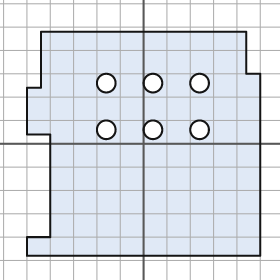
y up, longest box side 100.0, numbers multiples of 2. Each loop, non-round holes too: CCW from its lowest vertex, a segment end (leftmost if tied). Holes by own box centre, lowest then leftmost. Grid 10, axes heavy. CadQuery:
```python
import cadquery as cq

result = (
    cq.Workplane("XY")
    .moveTo(-50.0, -48.0)
    .lineTo(50.0, -48.0)
    .lineTo(50.0, 30.0)
    .lineTo(44.0, 30.0)
    .lineTo(44.0, 48.0)
    .lineTo(-44.0, 48.0)
    .lineTo(-44.0, 24.0)
    .lineTo(-50.0, 24.0)
    .lineTo(-50.0, 4.0)
    .lineTo(-40.0, 4.0)
    .lineTo(-40.0, -40.0)
    .lineTo(-50.0, -40.0)
    .close()
    .moveTo(-16.0, 6.0)
    .circle(4.0)
    .moveTo(4.0, 6.0)
    .circle(4.0)
    .moveTo(24.0, 6.0)
    .circle(4.0)
    .moveTo(-16.0, 26.0)
    .circle(4.0)
    .moveTo(4.0, 26.0)
    .circle(4.0)
    .moveTo(24.0, 26.0)
    .circle(4.0)
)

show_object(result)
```